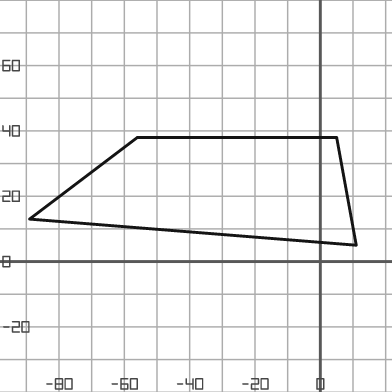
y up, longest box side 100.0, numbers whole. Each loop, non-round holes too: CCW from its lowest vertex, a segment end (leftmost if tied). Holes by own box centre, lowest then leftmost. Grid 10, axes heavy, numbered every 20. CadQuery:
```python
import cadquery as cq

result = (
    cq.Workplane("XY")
    .moveTo(11.0, 5.0)
    .lineTo(5.0, 38.0)
    .lineTo(-56.0, 38.0)
    .lineTo(-89.0, 13.0)
    .close()
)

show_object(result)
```